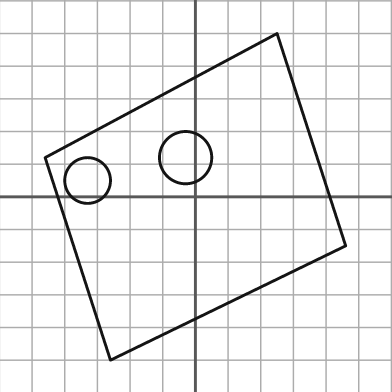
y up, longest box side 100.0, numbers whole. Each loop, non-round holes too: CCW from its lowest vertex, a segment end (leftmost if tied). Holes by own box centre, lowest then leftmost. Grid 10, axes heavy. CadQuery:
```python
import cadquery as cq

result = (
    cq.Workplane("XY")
    .moveTo(-26.0, -50.0)
    .lineTo(46.0, -15.0)
    .lineTo(25.0, 50.0)
    .lineTo(-46.0, 12.0)
    .close()
    .moveTo(-33.0, 5.0)
    .circle(7.0)
    .moveTo(-3.0, 12.0)
    .circle(8.0)
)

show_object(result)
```